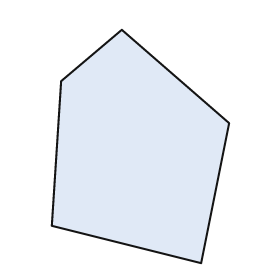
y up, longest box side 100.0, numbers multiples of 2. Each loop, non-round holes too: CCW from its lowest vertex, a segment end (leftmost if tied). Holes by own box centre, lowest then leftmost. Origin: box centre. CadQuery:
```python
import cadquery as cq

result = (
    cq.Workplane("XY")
    .moveTo(26.0, -50.0)
    .lineTo(38.0, 10.0)
    .lineTo(-8.0, 50.0)
    .lineTo(-34.0, 28.0)
    .lineTo(-38.0, -34.0)
    .close()
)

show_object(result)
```